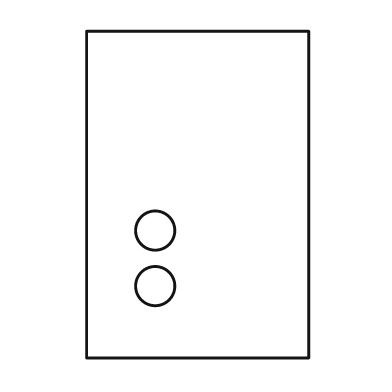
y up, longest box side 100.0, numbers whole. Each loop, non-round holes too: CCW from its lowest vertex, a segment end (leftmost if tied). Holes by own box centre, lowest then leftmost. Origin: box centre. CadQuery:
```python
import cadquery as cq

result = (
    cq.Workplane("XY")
    .moveTo(-34.0, -50.0)
    .lineTo(34.0, -50.0)
    .lineTo(34.0, 50.0)
    .lineTo(-34.0, 50.0)
    .close()
    .moveTo(-13.0, -28.0)
    .circle(6.0)
    .moveTo(-13.0, -11.0)
    .circle(6.0)
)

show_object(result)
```